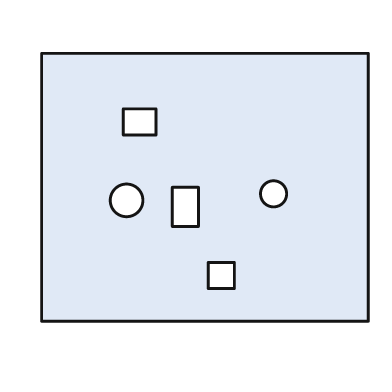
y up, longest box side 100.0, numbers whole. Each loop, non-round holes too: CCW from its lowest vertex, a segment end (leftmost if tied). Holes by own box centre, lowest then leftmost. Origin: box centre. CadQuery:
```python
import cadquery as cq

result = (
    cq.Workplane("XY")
    .moveTo(-50.0, -41.0)
    .lineTo(50.0, -41.0)
    .lineTo(50.0, 41.0)
    .lineTo(-50.0, 41.0)
    .close()
    .moveTo(1.0, -31.0)
    .lineTo(9.0, -31.0)
    .lineTo(9.0, -23.0)
    .lineTo(1.0, -23.0)
    .close()
    .moveTo(-10.0, -12.0)
    .lineTo(-2.0, -12.0)
    .lineTo(-2.0, 0.0)
    .lineTo(-10.0, 0.0)
    .close()
    .moveTo(-24.0, -4.0)
    .circle(5.0)
    .moveTo(21.0, -2.0)
    .circle(4.0)
    .moveTo(-25.0, 16.0)
    .lineTo(-15.0, 16.0)
    .lineTo(-15.0, 24.0)
    .lineTo(-25.0, 24.0)
    .close()
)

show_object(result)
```